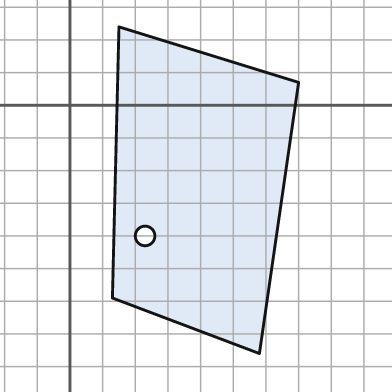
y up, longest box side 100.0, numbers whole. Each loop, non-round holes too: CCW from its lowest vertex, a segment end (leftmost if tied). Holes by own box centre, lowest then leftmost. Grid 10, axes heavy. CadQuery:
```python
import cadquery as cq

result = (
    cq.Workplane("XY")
    .moveTo(58.0, -76.0)
    .lineTo(70.0, 7.0)
    .lineTo(15.0, 24.0)
    .lineTo(13.0, -59.0)
    .close()
    .moveTo(23.0, -40.0)
    .circle(3.0)
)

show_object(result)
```